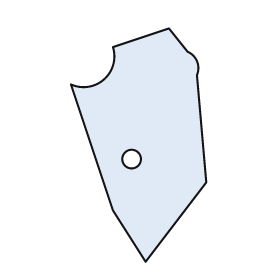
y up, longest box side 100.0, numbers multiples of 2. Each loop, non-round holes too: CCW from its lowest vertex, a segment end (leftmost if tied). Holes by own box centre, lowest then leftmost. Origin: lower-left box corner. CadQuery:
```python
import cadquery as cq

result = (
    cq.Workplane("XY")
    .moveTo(32.0, 0.0)
    .lineTo(58.0, 34.0)
    .lineTo(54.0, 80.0)
    .threePointArc((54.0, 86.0), (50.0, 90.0))
    .lineTo(42.0, 100.0)
    .lineTo(18.0, 92.0)
    .threePointArc((14.0, 78.0), (0.0, 76.0))
    .lineTo(18.0, 22.0)
    .close()
    .moveTo(26.0, 44.0)
    .circle(4.0)
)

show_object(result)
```